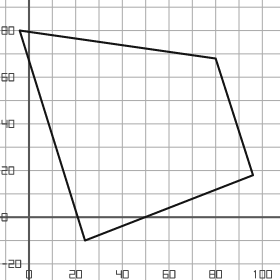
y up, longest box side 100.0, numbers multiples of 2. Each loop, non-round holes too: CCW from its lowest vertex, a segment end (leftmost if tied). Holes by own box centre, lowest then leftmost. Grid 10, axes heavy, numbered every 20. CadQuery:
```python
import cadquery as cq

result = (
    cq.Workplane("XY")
    .moveTo(24.0, -10.0)
    .lineTo(96.0, 18.0)
    .lineTo(80.0, 68.0)
    .lineTo(-4.0, 80.0)
    .close()
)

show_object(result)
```